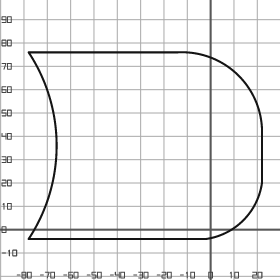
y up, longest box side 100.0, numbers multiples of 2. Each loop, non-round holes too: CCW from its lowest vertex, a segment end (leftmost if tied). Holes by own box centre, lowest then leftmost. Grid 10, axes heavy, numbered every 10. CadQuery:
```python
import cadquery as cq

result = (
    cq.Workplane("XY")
    .moveTo(-78.0, -4.0)
    .lineTo(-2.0, -4.0)
    .threePointArc((14.0, 4.0), (22.0, 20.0))
    .lineTo(22.0, 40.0)
    .threePointArc((12.0, 66.0), (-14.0, 76.0))
    .lineTo(-78.0, 76.0)
    .threePointArc((-66.0, 36.0), (-78.0, -4.0))
    .close()
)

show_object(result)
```